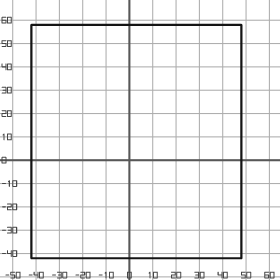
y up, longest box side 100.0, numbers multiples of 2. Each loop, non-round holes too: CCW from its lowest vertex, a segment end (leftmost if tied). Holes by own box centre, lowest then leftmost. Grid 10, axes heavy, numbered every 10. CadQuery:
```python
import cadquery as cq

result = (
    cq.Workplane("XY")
    .moveTo(-42.0, -42.0)
    .lineTo(48.0, -42.0)
    .lineTo(48.0, 58.0)
    .lineTo(-42.0, 58.0)
    .close()
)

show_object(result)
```